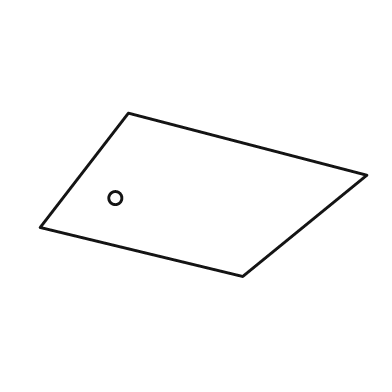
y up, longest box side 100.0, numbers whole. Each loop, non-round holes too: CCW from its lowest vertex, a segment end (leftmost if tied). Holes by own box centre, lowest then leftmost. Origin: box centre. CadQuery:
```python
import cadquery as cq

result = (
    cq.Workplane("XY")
    .moveTo(12.0, -25.0)
    .lineTo(50.0, 6.0)
    .lineTo(-23.0, 25.0)
    .lineTo(-50.0, -10.0)
    .close()
    .moveTo(-27.0, -1.0)
    .circle(2.0)
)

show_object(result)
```